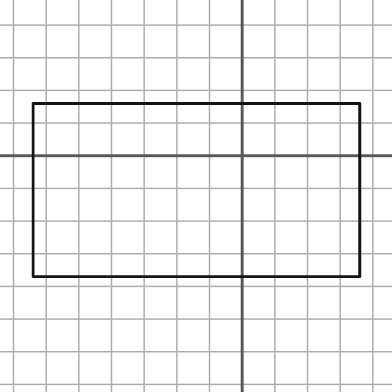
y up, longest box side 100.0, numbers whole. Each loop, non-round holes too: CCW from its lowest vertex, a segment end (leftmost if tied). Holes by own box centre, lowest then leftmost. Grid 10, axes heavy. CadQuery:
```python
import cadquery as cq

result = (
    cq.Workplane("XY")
    .moveTo(-64.0, -37.0)
    .lineTo(36.0, -37.0)
    .lineTo(36.0, 16.0)
    .lineTo(-64.0, 16.0)
    .close()
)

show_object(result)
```